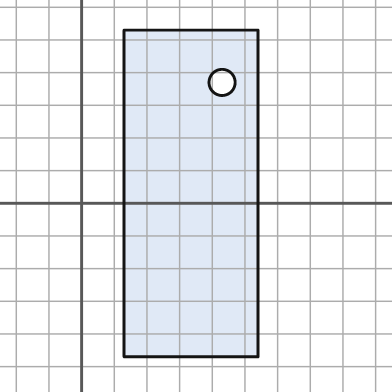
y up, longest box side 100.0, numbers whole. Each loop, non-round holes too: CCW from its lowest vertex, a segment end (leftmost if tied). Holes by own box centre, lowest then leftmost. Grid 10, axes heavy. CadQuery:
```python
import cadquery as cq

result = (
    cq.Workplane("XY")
    .moveTo(13.0, -47.0)
    .lineTo(54.0, -47.0)
    .lineTo(54.0, 53.0)
    .lineTo(13.0, 53.0)
    .close()
    .moveTo(43.0, 37.0)
    .circle(4.0)
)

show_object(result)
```